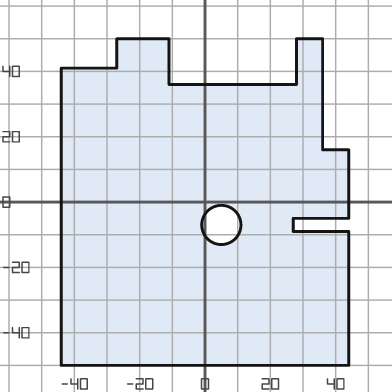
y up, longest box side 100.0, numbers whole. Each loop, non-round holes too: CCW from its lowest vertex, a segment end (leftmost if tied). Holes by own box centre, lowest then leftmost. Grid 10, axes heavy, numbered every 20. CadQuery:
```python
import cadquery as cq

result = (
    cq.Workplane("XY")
    .moveTo(-44.0, -50.0)
    .lineTo(44.0, -50.0)
    .lineTo(44.0, -9.0)
    .lineTo(27.0, -9.0)
    .lineTo(27.0, -5.0)
    .lineTo(44.0, -5.0)
    .lineTo(44.0, 16.0)
    .lineTo(36.0, 16.0)
    .lineTo(36.0, 50.0)
    .lineTo(28.0, 50.0)
    .lineTo(28.0, 36.0)
    .lineTo(-11.0, 36.0)
    .lineTo(-11.0, 50.0)
    .lineTo(-27.0, 50.0)
    .lineTo(-27.0, 41.0)
    .lineTo(-44.0, 41.0)
    .close()
    .moveTo(5.0, -7.0)
    .circle(6.0)
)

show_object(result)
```